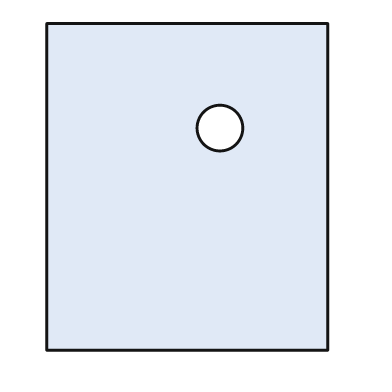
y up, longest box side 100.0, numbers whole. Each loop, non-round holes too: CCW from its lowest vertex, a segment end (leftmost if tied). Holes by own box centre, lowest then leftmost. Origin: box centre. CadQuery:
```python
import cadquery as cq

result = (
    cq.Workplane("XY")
    .moveTo(-43.0, -50.0)
    .lineTo(43.0, -50.0)
    .lineTo(43.0, 50.0)
    .lineTo(-43.0, 50.0)
    .close()
    .moveTo(10.0, 18.0)
    .circle(7.0)
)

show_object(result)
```